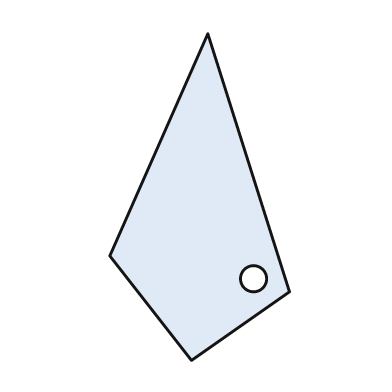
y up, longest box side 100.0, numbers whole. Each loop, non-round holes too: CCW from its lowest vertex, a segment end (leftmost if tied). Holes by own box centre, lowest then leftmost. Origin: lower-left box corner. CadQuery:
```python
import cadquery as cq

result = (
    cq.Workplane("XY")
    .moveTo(25.0, 0.0)
    .lineTo(55.0, 21.0)
    .lineTo(30.0, 100.0)
    .lineTo(0.0, 32.0)
    .close()
    .moveTo(44.0, 25.0)
    .circle(4.0)
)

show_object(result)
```